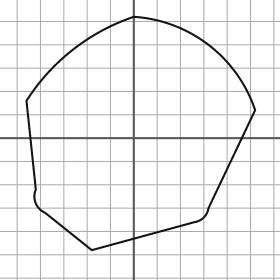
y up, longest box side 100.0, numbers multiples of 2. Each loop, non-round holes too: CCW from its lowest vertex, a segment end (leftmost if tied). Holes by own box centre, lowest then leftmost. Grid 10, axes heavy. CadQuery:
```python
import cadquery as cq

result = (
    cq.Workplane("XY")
    .moveTo(-18.0, -48.0)
    .lineTo(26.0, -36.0)
    .threePointArc((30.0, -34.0), (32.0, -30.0))
    .lineTo(52.0, 12.0)
    .threePointArc((32.0, 40.0), (0.0, 52.0))
    .threePointArc((-26.0, 38.0), (-46.0, 16.0))
    .lineTo(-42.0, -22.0)
    .threePointArc((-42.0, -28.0), (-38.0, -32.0))
    .close()
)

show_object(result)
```